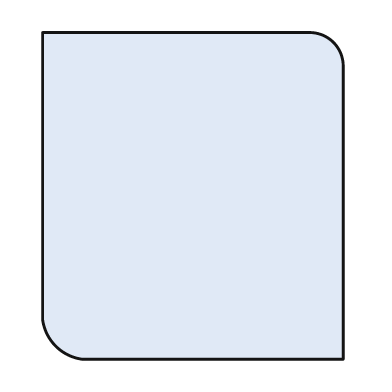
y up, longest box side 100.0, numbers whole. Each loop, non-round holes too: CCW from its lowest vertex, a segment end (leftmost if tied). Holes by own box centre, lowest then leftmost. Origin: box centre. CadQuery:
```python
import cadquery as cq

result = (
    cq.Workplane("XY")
    .moveTo(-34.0, -50.0)
    .lineTo(46.0, -50.0)
    .lineTo(46.0, 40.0)
    .threePointArc((43.0, 47.0), (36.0, 50.0))
    .lineTo(-46.0, 50.0)
    .lineTo(-46.0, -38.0)
    .threePointArc((-42.0, -46.0), (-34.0, -50.0))
    .close()
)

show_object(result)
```